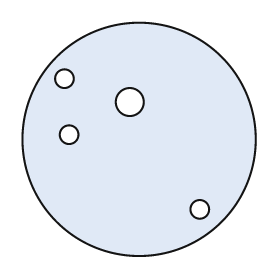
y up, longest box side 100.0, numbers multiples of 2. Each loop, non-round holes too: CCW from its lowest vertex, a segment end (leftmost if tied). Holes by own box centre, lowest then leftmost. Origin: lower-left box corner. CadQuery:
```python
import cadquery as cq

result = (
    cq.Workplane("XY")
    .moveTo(50.0, 50.0)
    .circle(50.0)
    .moveTo(76.0, 20.0)
    .circle(4.0)
    .moveTo(20.0, 52.0)
    .circle(4.0)
    .moveTo(46.0, 66.0)
    .circle(6.0)
    .moveTo(18.0, 76.0)
    .circle(4.0)
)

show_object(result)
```